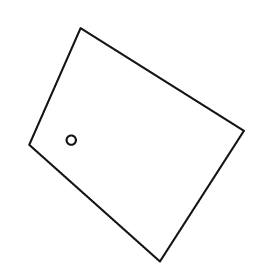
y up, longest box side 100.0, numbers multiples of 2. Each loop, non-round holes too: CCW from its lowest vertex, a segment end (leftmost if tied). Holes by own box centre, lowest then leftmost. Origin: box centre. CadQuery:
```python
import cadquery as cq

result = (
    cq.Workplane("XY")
    .moveTo(10.0, -50.0)
    .lineTo(46.0, 6.0)
    .lineTo(-24.0, 50.0)
    .lineTo(-46.0, 0.0)
    .close()
    .moveTo(-28.0, 2.0)
    .circle(2.0)
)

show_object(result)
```